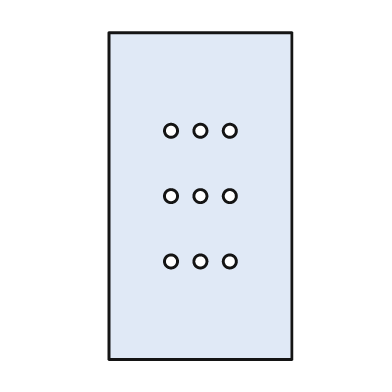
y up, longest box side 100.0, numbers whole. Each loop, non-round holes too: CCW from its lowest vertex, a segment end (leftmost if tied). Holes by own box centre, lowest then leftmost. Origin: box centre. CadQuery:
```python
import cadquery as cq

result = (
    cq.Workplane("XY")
    .moveTo(-28.0, -50.0)
    .lineTo(28.0, -50.0)
    .lineTo(28.0, 50.0)
    .lineTo(-28.0, 50.0)
    .close()
    .moveTo(-9.0, -20.0)
    .circle(2.0)
    .moveTo(0.0, -20.0)
    .circle(2.0)
    .moveTo(9.0, -20.0)
    .circle(2.0)
    .moveTo(-9.0, 0.0)
    .circle(2.0)
    .moveTo(0.0, 0.0)
    .circle(2.0)
    .moveTo(9.0, 0.0)
    .circle(2.0)
    .moveTo(-9.0, 20.0)
    .circle(2.0)
    .moveTo(0.0, 20.0)
    .circle(2.0)
    .moveTo(9.0, 20.0)
    .circle(2.0)
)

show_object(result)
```